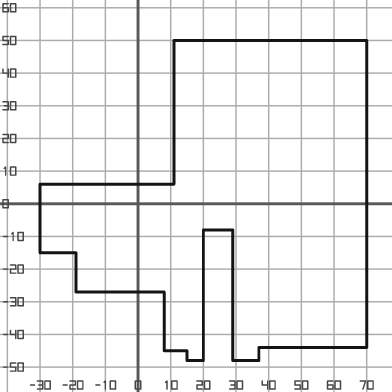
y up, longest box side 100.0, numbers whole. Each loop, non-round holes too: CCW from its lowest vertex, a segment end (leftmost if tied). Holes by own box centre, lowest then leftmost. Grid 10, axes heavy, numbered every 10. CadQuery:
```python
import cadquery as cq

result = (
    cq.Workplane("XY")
    .moveTo(15.0, -48.0)
    .lineTo(20.0, -48.0)
    .lineTo(20.0, -8.0)
    .lineTo(29.0, -8.0)
    .lineTo(29.0, -48.0)
    .lineTo(37.0, -48.0)
    .lineTo(37.0, -44.0)
    .lineTo(70.0, -44.0)
    .lineTo(70.0, 50.0)
    .lineTo(11.0, 50.0)
    .lineTo(11.0, 6.0)
    .lineTo(-30.0, 6.0)
    .lineTo(-30.0, -15.0)
    .lineTo(-19.0, -15.0)
    .lineTo(-19.0, -27.0)
    .lineTo(8.0, -27.0)
    .lineTo(8.0, -45.0)
    .lineTo(15.0, -45.0)
    .close()
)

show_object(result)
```